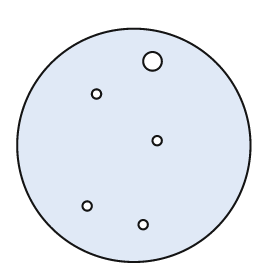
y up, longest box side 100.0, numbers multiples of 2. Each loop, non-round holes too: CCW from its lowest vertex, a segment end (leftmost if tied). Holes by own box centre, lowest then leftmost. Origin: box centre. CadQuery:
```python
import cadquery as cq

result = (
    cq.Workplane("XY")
    .moveTo(0.0, 0.0)
    .circle(50.0)
    .moveTo(4.0, -34.0)
    .circle(2.0)
    .moveTo(-20.0, -26.0)
    .circle(2.0)
    .moveTo(10.0, 2.0)
    .circle(2.0)
    .moveTo(-16.0, 22.0)
    .circle(2.0)
    .moveTo(8.0, 36.0)
    .circle(4.0)
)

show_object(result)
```